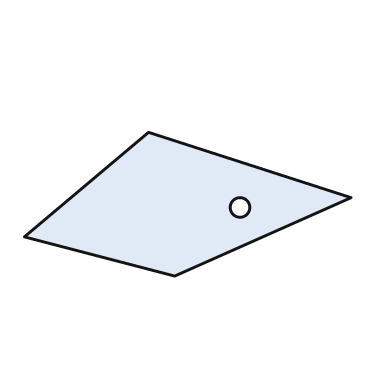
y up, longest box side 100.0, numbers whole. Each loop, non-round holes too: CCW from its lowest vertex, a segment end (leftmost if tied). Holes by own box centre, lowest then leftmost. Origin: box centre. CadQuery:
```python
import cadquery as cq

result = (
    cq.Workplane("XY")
    .moveTo(-4.0, -22.0)
    .lineTo(50.0, 2.0)
    .lineTo(-12.0, 22.0)
    .lineTo(-50.0, -10.0)
    .close()
    .moveTo(16.0, -1.0)
    .circle(3.0)
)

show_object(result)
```